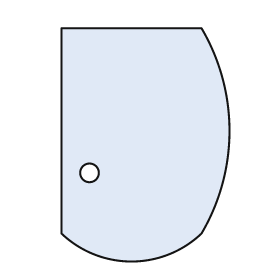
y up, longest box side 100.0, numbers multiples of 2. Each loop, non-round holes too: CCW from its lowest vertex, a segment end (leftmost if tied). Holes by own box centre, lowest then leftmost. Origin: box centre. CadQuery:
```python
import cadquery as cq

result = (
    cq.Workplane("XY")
    .moveTo(-36.0, -38.0)
    .threePointArc((-6.0, -50.0), (24.0, -38.0))
    .threePointArc((36.0, 6.0), (24.0, 50.0))
    .lineTo(-36.0, 50.0)
    .close()
    .moveTo(-24.0, -12.0)
    .circle(4.0)
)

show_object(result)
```